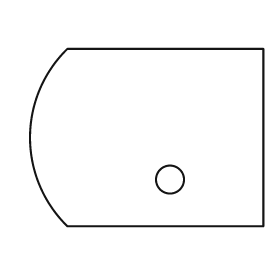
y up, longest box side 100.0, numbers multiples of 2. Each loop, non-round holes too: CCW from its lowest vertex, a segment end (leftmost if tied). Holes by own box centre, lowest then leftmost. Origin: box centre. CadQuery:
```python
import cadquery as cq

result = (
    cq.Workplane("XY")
    .moveTo(-34.0, -38.0)
    .lineTo(50.0, -38.0)
    .lineTo(50.0, 38.0)
    .lineTo(-34.0, 38.0)
    .threePointArc((-50.0, 0.0), (-34.0, -38.0))
    .close()
    .moveTo(10.0, -18.0)
    .circle(6.0)
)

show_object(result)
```